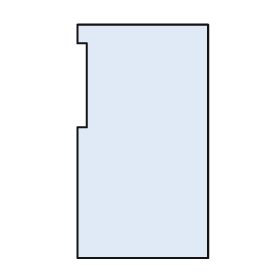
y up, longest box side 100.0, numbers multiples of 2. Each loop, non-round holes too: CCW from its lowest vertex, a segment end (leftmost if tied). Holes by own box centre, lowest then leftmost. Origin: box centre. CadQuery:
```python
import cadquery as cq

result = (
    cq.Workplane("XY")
    .moveTo(-28.0, -50.0)
    .lineTo(28.0, -50.0)
    .lineTo(28.0, 50.0)
    .lineTo(-28.0, 50.0)
    .lineTo(-28.0, 42.0)
    .lineTo(-24.0, 42.0)
    .lineTo(-24.0, 6.0)
    .lineTo(-28.0, 6.0)
    .close()
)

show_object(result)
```